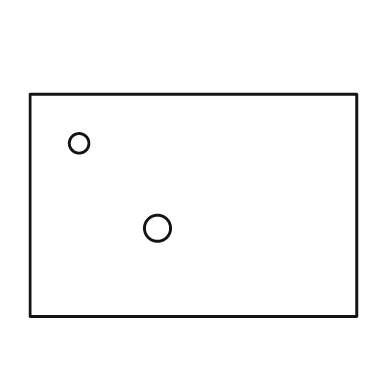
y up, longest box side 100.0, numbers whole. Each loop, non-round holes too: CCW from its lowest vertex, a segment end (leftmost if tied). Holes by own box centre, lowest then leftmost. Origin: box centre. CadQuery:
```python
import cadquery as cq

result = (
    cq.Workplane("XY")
    .moveTo(-50.0, -34.0)
    .lineTo(50.0, -34.0)
    .lineTo(50.0, 34.0)
    .lineTo(-50.0, 34.0)
    .close()
    .moveTo(-11.0, -7.0)
    .circle(4.0)
    .moveTo(-35.0, 19.0)
    .circle(3.0)
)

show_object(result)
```